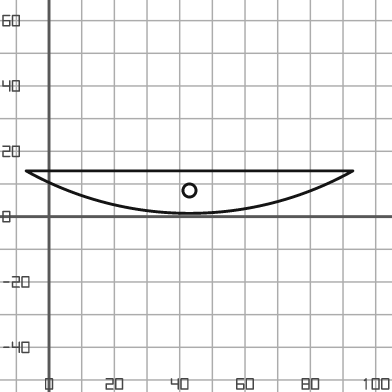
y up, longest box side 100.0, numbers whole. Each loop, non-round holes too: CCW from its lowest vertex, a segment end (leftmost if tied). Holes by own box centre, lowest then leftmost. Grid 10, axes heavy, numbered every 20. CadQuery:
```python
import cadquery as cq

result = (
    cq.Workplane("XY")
    .moveTo(-7.0, 14.0)
    .threePointArc((43.0, 1.0), (93.0, 14.0))
    .close()
    .moveTo(43.0, 8.0)
    .circle(2.0)
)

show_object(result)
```